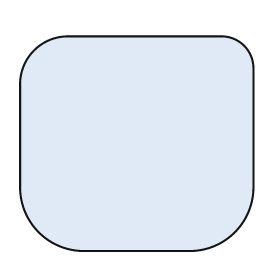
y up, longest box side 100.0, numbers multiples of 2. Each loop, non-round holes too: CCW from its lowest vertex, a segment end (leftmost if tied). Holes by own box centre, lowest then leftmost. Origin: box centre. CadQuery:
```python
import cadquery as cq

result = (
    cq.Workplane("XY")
    .moveTo(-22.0, -46.0)
    .lineTo(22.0, -46.0)
    .threePointArc((42.0, -38.0), (50.0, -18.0))
    .lineTo(50.0, 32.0)
    .threePointArc((46.0, 42.0), (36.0, 46.0))
    .lineTo(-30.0, 46.0)
    .threePointArc((-44.0, 40.0), (-50.0, 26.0))
    .lineTo(-50.0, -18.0)
    .threePointArc((-42.0, -38.0), (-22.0, -46.0))
    .close()
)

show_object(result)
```